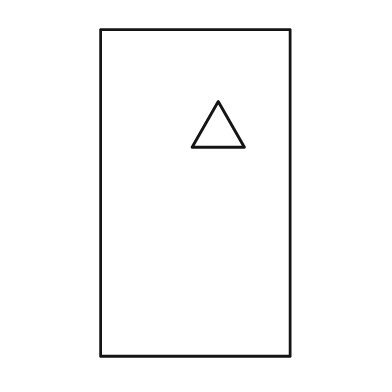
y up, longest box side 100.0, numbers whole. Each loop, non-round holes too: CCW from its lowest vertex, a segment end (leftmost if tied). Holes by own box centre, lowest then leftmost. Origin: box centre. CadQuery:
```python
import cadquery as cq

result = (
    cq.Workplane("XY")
    .moveTo(-29.0, -50.0)
    .lineTo(29.0, -50.0)
    .lineTo(29.0, 50.0)
    .lineTo(-29.0, 50.0)
    .close()
    .moveTo(-1.0, 14.0)
    .lineTo(15.0, 14.0)
    .lineTo(7.0, 28.0)
    .close()
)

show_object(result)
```